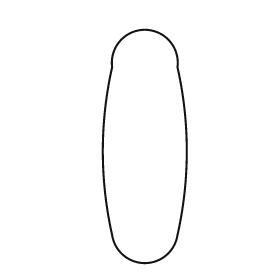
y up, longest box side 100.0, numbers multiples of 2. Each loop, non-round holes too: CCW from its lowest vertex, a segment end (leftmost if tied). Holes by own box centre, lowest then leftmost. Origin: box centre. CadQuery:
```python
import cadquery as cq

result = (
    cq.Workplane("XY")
    .moveTo(-14.0, -38.0)
    .threePointArc((0.0, -50.0), (14.0, -38.0))
    .threePointArc((18.0, -2.0), (14.0, 34.0))
    .threePointArc((0.0, 50.0), (-14.0, 34.0))
    .threePointArc((-18.0, -2.0), (-14.0, -38.0))
    .close()
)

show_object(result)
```